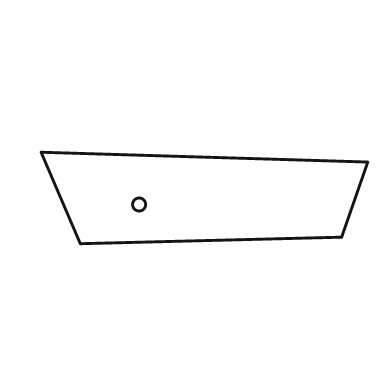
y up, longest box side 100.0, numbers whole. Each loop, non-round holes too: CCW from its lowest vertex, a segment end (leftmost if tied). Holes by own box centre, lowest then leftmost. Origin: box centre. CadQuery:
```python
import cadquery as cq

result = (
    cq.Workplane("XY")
    .moveTo(-38.0, -14.0)
    .lineTo(42.0, -12.0)
    .lineTo(50.0, 11.0)
    .lineTo(-50.0, 14.0)
    .close()
    .moveTo(-20.0, -2.0)
    .circle(2.0)
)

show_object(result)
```